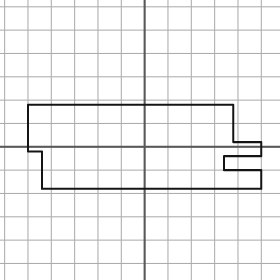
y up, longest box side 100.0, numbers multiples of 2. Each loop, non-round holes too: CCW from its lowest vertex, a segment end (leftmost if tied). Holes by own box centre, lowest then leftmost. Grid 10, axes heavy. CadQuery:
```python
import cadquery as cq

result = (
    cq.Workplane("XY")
    .moveTo(-44.0, -18.0)
    .lineTo(50.0, -18.0)
    .lineTo(50.0, -10.0)
    .lineTo(34.0, -10.0)
    .lineTo(34.0, -4.0)
    .lineTo(50.0, -4.0)
    .lineTo(50.0, 2.0)
    .lineTo(38.0, 2.0)
    .lineTo(38.0, 18.0)
    .lineTo(-50.0, 18.0)
    .lineTo(-50.0, -2.0)
    .lineTo(-44.0, -2.0)
    .close()
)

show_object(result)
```